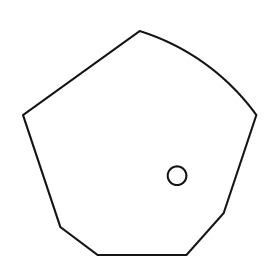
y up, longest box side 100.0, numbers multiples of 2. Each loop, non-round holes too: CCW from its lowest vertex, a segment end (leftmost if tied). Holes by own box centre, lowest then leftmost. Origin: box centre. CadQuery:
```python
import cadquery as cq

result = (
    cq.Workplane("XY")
    .moveTo(-18.0, -48.0)
    .lineTo(20.0, -48.0)
    .lineTo(36.0, -30.0)
    .lineTo(50.0, 12.0)
    .threePointArc((28.0, 34.0), (0.0, 48.0))
    .lineTo(-50.0, 12.0)
    .lineTo(-34.0, -36.0)
    .close()
    .moveTo(16.0, -14.0)
    .circle(4.0)
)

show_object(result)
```